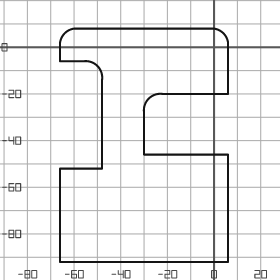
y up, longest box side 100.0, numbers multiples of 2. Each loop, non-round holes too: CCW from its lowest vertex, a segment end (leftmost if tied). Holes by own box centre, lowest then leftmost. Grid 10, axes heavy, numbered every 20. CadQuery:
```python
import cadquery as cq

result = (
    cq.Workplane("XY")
    .moveTo(-66.0, -92.0)
    .lineTo(6.0, -92.0)
    .lineTo(6.0, -46.0)
    .lineTo(-30.0, -46.0)
    .lineTo(-30.0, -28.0)
    .threePointArc((-28.0, -22.0), (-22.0, -20.0))
    .lineTo(6.0, -20.0)
    .lineTo(6.0, 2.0)
    .threePointArc((4.0, 6.0), (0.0, 8.0))
    .lineTo(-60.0, 8.0)
    .threePointArc((-64.0, 6.0), (-66.0, 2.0))
    .lineTo(-66.0, -6.0)
    .lineTo(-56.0, -6.0)
    .threePointArc((-50.0, -8.0), (-48.0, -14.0))
    .lineTo(-48.0, -52.0)
    .lineTo(-66.0, -52.0)
    .close()
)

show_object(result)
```